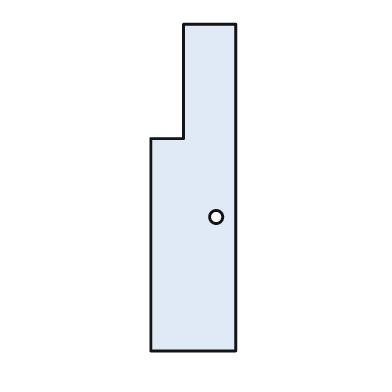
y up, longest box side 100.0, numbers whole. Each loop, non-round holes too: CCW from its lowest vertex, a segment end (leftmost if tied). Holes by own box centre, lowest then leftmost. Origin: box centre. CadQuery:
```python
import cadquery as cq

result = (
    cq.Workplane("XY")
    .moveTo(-13.0, -50.0)
    .lineTo(13.0, -50.0)
    .lineTo(13.0, 50.0)
    .lineTo(-3.0, 50.0)
    .lineTo(-3.0, 15.0)
    .lineTo(-13.0, 15.0)
    .close()
    .moveTo(7.0, -9.0)
    .circle(2.0)
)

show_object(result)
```